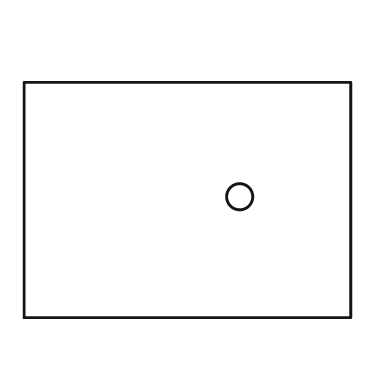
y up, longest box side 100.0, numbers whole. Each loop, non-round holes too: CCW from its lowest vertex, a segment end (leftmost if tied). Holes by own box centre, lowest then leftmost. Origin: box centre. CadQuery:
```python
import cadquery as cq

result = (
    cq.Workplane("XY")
    .moveTo(-50.0, -36.0)
    .lineTo(50.0, -36.0)
    .lineTo(50.0, 36.0)
    .lineTo(-50.0, 36.0)
    .close()
    .moveTo(16.0, 1.0)
    .circle(4.0)
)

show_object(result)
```